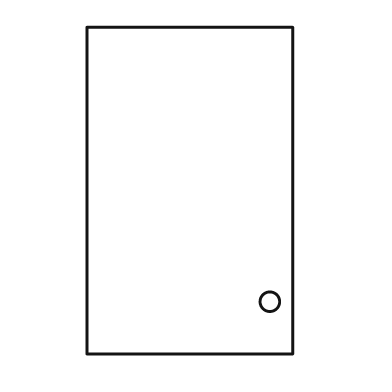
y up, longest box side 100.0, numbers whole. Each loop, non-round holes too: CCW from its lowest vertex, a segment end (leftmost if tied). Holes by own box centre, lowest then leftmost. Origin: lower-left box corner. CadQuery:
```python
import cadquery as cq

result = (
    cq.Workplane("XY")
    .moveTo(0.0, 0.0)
    .lineTo(63.0, 0.0)
    .lineTo(63.0, 100.0)
    .lineTo(0.0, 100.0)
    .close()
    .moveTo(56.0, 16.0)
    .circle(3.0)
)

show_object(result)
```